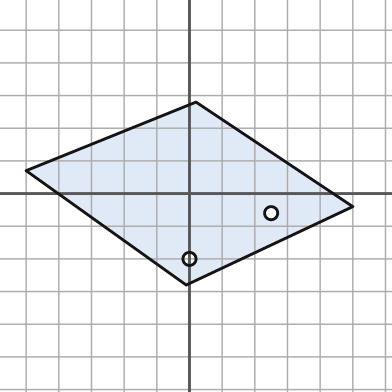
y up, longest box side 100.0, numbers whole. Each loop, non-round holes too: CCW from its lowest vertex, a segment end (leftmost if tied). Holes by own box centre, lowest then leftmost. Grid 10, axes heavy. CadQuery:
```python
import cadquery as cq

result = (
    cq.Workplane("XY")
    .moveTo(-1.0, -28.0)
    .lineTo(50.0, -4.0)
    .lineTo(2.0, 28.0)
    .lineTo(-50.0, 7.0)
    .close()
    .moveTo(0.0, -20.0)
    .circle(2.0)
    .moveTo(25.0, -6.0)
    .circle(2.0)
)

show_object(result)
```